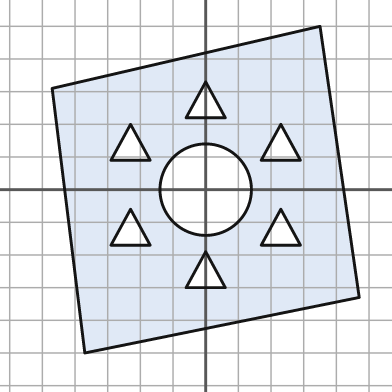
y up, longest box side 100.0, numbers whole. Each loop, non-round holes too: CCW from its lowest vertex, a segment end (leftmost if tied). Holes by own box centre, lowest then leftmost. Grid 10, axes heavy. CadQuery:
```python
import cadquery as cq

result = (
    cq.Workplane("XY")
    .moveTo(-37.0, -50.0)
    .lineTo(47.0, -33.0)
    .lineTo(35.0, 50.0)
    .lineTo(-47.0, 31.0)
    .close()
    .moveTo(-6.0, -30.0)
    .lineTo(6.0, -30.0)
    .lineTo(0.0, -19.0)
    .close()
    .moveTo(-29.0, -17.0)
    .lineTo(-17.0, -17.0)
    .lineTo(-23.0, -6.0)
    .close()
    .moveTo(17.0, -17.0)
    .lineTo(29.0, -17.0)
    .lineTo(23.0, -6.0)
    .close()
    .moveTo(0.0, 0.0)
    .circle(14.0)
    .moveTo(-29.0, 9.0)
    .lineTo(-17.0, 9.0)
    .lineTo(-23.0, 20.0)
    .close()
    .moveTo(17.0, 9.0)
    .lineTo(29.0, 9.0)
    .lineTo(23.0, 20.0)
    .close()
    .moveTo(-6.0, 22.0)
    .lineTo(6.0, 22.0)
    .lineTo(0.0, 33.0)
    .close()
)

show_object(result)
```